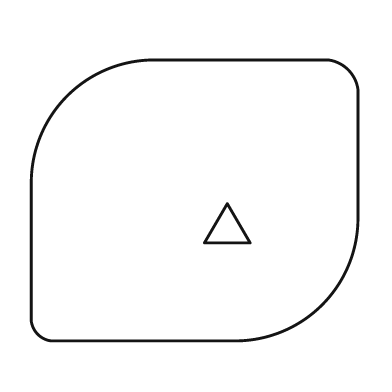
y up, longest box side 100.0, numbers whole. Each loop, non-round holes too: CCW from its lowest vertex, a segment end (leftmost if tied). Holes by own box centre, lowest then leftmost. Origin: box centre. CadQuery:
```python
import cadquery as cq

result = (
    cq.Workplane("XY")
    .moveTo(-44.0, -43.0)
    .lineTo(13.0, -43.0)
    .threePointArc((39.0, -32.0), (50.0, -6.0))
    .lineTo(50.0, 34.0)
    .threePointArc((47.0, 40.0), (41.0, 43.0))
    .lineTo(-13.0, 43.0)
    .threePointArc((-39.0, 32.0), (-50.0, 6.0))
    .lineTo(-50.0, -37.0)
    .threePointArc((-48.0, -41.0), (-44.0, -43.0))
    .close()
    .moveTo(3.0, -13.0)
    .lineTo(17.0, -13.0)
    .lineTo(10.0, -1.0)
    .close()
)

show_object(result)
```